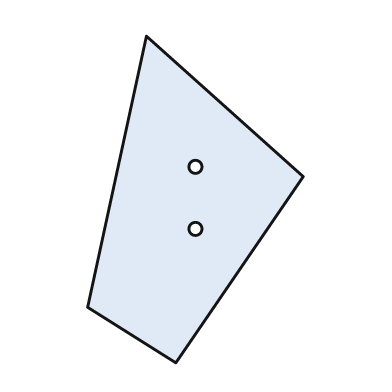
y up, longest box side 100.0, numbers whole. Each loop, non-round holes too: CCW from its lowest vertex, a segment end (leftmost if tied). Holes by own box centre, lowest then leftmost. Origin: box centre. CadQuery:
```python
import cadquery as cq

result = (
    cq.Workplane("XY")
    .moveTo(-6.0, -50.0)
    .lineTo(33.0, 7.0)
    .lineTo(-15.0, 50.0)
    .lineTo(-33.0, -33.0)
    .close()
    .moveTo(0.0, -9.0)
    .circle(2.0)
    .moveTo(0.0, 10.0)
    .circle(2.0)
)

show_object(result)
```